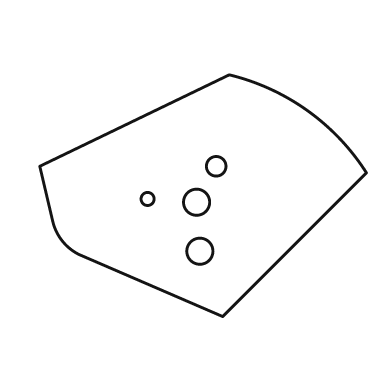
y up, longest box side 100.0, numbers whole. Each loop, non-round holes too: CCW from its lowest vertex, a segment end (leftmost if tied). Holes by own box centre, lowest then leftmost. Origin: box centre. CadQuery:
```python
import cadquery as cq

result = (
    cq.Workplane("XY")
    .moveTo(6.0, -37.0)
    .lineTo(50.0, 7.0)
    .threePointArc((32.0, 26.0), (8.0, 37.0))
    .lineTo(-50.0, 9.0)
    .lineTo(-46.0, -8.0)
    .threePointArc((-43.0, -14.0), (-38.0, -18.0))
    .close()
    .moveTo(-1.0, -17.0)
    .circle(4.0)
    .moveTo(-2.0, -2.0)
    .circle(4.0)
    .moveTo(-17.0, -1.0)
    .circle(2.0)
    .moveTo(4.0, 9.0)
    .circle(3.0)
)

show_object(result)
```